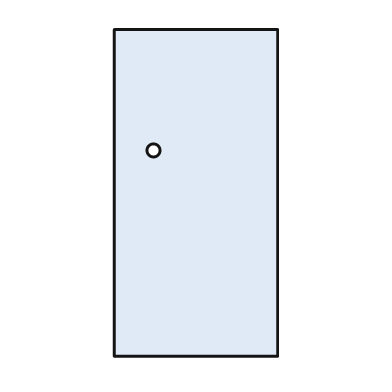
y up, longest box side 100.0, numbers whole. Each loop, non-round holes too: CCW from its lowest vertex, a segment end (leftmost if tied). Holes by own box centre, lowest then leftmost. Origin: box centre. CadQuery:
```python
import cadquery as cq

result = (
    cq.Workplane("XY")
    .moveTo(-25.0, -50.0)
    .lineTo(25.0, -50.0)
    .lineTo(25.0, 50.0)
    .lineTo(-25.0, 50.0)
    .close()
    .moveTo(-13.0, 13.0)
    .circle(2.0)
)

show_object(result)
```